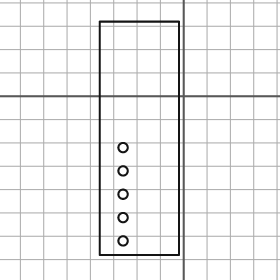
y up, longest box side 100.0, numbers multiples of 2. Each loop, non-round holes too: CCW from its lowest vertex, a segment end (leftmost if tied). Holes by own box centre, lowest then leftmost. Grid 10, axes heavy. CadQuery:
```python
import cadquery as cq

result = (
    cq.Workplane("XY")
    .moveTo(-36.0, -68.0)
    .lineTo(-2.0, -68.0)
    .lineTo(-2.0, 32.0)
    .lineTo(-36.0, 32.0)
    .close()
    .moveTo(-26.0, -62.0)
    .circle(2.0)
    .moveTo(-26.0, -52.0)
    .circle(2.0)
    .moveTo(-26.0, -42.0)
    .circle(2.0)
    .moveTo(-26.0, -32.0)
    .circle(2.0)
    .moveTo(-26.0, -22.0)
    .circle(2.0)
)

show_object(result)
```